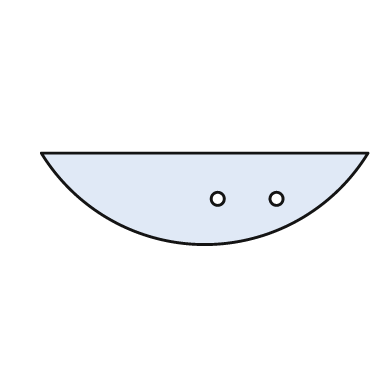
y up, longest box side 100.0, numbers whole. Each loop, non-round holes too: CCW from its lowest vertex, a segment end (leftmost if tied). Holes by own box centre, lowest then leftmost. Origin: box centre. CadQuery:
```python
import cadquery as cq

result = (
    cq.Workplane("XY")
    .moveTo(-50.0, 14.0)
    .threePointArc((0.0, -14.0), (50.0, 14.0))
    .close()
    .moveTo(4.0, 0.0)
    .circle(2.0)
    .moveTo(22.0, 0.0)
    .circle(2.0)
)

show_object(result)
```